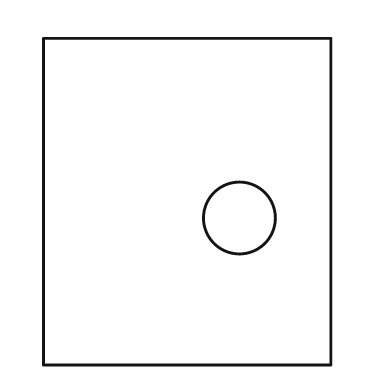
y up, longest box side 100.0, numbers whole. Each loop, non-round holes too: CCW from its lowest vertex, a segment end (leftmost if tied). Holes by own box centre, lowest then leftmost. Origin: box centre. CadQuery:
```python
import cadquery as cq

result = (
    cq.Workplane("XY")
    .moveTo(-44.0, -50.0)
    .lineTo(44.0, -50.0)
    .lineTo(44.0, 50.0)
    .lineTo(-44.0, 50.0)
    .close()
    .moveTo(16.0, -5.0)
    .circle(11.0)
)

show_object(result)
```